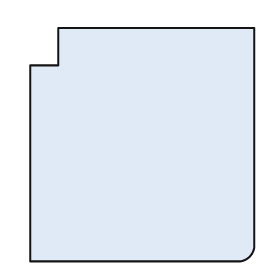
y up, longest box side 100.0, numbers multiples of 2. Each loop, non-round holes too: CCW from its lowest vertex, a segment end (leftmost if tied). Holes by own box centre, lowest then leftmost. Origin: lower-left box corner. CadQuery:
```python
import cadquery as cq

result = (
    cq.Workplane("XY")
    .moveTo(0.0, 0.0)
    .lineTo(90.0, 0.0)
    .threePointArc((94.0, 2.0), (96.0, 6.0))
    .lineTo(96.0, 100.0)
    .lineTo(12.0, 100.0)
    .lineTo(12.0, 84.0)
    .lineTo(0.0, 84.0)
    .close()
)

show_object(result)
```